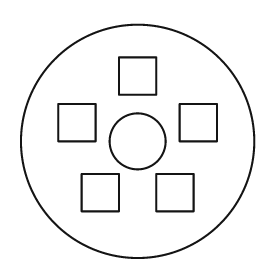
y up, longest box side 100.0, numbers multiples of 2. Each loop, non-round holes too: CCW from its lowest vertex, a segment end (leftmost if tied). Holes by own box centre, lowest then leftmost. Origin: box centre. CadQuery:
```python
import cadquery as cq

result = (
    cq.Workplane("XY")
    .moveTo(0.0, 0.0)
    .circle(50.0)
    .moveTo(-24.0, -30.0)
    .lineTo(-8.0, -30.0)
    .lineTo(-8.0, -14.0)
    .lineTo(-24.0, -14.0)
    .close()
    .moveTo(8.0, -30.0)
    .lineTo(24.0, -30.0)
    .lineTo(24.0, -14.0)
    .lineTo(8.0, -14.0)
    .close()
    .moveTo(0.0, 0.0)
    .circle(12.0)
    .moveTo(-34.0, 0.0)
    .lineTo(-18.0, 0.0)
    .lineTo(-18.0, 16.0)
    .lineTo(-34.0, 16.0)
    .close()
    .moveTo(18.0, 0.0)
    .lineTo(34.0, 0.0)
    .lineTo(34.0, 16.0)
    .lineTo(18.0, 16.0)
    .close()
    .moveTo(-8.0, 20.0)
    .lineTo(8.0, 20.0)
    .lineTo(8.0, 36.0)
    .lineTo(-8.0, 36.0)
    .close()
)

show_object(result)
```